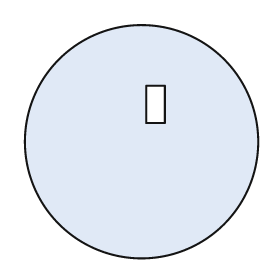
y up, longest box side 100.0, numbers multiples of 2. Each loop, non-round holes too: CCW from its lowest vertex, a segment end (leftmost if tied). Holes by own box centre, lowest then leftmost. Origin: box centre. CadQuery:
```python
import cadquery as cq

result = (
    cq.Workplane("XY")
    .moveTo(0.0, 0.0)
    .circle(50.0)
    .moveTo(2.0, 8.0)
    .lineTo(10.0, 8.0)
    .lineTo(10.0, 24.0)
    .lineTo(2.0, 24.0)
    .close()
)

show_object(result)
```